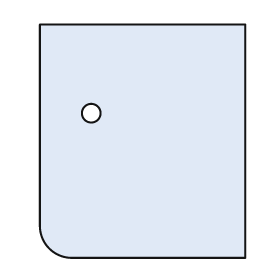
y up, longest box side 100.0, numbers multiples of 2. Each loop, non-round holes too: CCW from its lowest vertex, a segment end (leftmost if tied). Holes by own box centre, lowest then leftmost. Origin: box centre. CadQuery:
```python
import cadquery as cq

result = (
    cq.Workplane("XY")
    .moveTo(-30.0, -50.0)
    .lineTo(44.0, -50.0)
    .lineTo(44.0, 50.0)
    .lineTo(-44.0, 50.0)
    .lineTo(-44.0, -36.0)
    .threePointArc((-40.0, -46.0), (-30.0, -50.0))
    .close()
    .moveTo(-22.0, 12.0)
    .circle(4.0)
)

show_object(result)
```